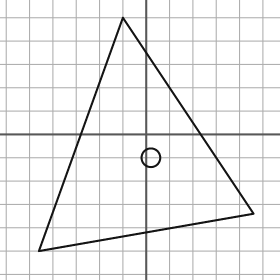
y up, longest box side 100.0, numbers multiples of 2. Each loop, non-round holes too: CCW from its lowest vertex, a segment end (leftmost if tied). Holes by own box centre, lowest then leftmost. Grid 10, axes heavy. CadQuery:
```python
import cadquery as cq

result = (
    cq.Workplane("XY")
    .moveTo(-46.0, -50.0)
    .lineTo(46.0, -34.0)
    .lineTo(-10.0, 50.0)
    .close()
    .moveTo(2.0, -10.0)
    .circle(4.0)
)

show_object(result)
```